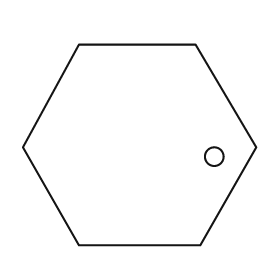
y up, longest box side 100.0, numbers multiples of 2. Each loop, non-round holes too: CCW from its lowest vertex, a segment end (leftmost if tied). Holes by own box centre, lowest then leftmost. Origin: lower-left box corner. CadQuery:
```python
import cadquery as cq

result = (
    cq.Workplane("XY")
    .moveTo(24.0, 0.0)
    .lineTo(76.0, 0.0)
    .lineTo(100.0, 42.0)
    .lineTo(74.0, 86.0)
    .lineTo(24.0, 86.0)
    .lineTo(0.0, 42.0)
    .close()
    .moveTo(82.0, 38.0)
    .circle(4.0)
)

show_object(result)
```